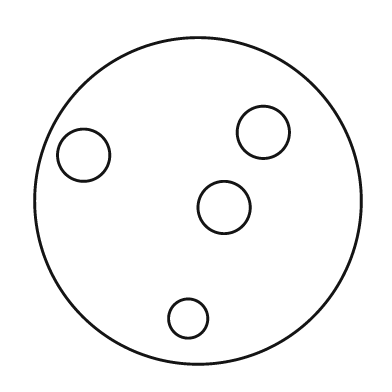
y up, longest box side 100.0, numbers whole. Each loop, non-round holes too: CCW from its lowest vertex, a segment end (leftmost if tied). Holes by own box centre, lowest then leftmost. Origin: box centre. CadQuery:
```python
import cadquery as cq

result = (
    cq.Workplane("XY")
    .moveTo(0.0, 0.0)
    .circle(50.0)
    .moveTo(-3.0, -36.0)
    .circle(6.0)
    .moveTo(8.0, -2.0)
    .circle(8.0)
    .moveTo(-35.0, 14.0)
    .circle(8.0)
    .moveTo(20.0, 21.0)
    .circle(8.0)
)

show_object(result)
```